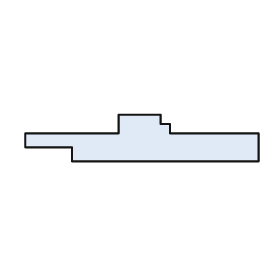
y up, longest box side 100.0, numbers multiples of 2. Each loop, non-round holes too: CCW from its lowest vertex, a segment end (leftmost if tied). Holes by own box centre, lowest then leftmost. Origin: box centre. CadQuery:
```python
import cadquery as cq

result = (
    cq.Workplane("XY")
    .moveTo(-30.0, -10.0)
    .lineTo(50.0, -10.0)
    .lineTo(50.0, 2.0)
    .lineTo(12.0, 2.0)
    .lineTo(12.0, 6.0)
    .lineTo(8.0, 6.0)
    .lineTo(8.0, 10.0)
    .lineTo(-10.0, 10.0)
    .lineTo(-10.0, 2.0)
    .lineTo(-50.0, 2.0)
    .lineTo(-50.0, -4.0)
    .lineTo(-30.0, -4.0)
    .close()
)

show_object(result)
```